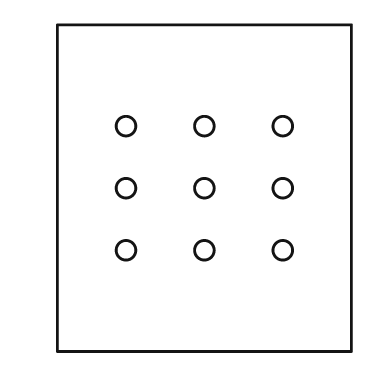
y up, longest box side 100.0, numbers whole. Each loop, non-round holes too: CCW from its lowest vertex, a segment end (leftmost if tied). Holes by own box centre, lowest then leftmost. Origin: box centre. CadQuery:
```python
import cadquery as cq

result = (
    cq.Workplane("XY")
    .moveTo(-45.0, -50.0)
    .lineTo(45.0, -50.0)
    .lineTo(45.0, 50.0)
    .lineTo(-45.0, 50.0)
    .close()
    .moveTo(-24.0, -19.0)
    .circle(3.0)
    .moveTo(0.0, -19.0)
    .circle(3.0)
    .moveTo(24.0, -19.0)
    .circle(3.0)
    .moveTo(-24.0, 0.0)
    .circle(3.0)
    .moveTo(0.0, 0.0)
    .circle(3.0)
    .moveTo(24.0, 0.0)
    .circle(3.0)
    .moveTo(-24.0, 19.0)
    .circle(3.0)
    .moveTo(0.0, 19.0)
    .circle(3.0)
    .moveTo(24.0, 19.0)
    .circle(3.0)
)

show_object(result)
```